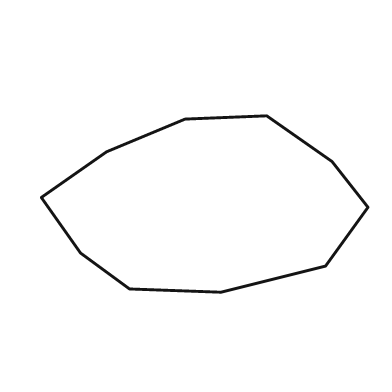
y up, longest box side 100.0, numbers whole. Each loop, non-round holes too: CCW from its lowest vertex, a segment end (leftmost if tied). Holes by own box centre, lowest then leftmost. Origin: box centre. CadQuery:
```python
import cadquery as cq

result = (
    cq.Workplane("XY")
    .moveTo(5.0, -27.0)
    .lineTo(37.0, -19.0)
    .lineTo(50.0, -1.0)
    .lineTo(39.0, 13.0)
    .lineTo(19.0, 27.0)
    .lineTo(-6.0, 26.0)
    .lineTo(-30.0, 16.0)
    .lineTo(-50.0, 2.0)
    .lineTo(-38.0, -15.0)
    .lineTo(-23.0, -26.0)
    .close()
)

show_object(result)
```